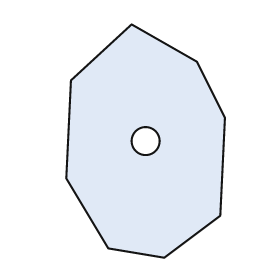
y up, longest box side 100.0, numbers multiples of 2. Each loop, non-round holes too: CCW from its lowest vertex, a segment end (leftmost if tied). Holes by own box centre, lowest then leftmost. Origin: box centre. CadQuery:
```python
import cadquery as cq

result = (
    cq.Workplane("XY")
    .moveTo(8.0, -50.0)
    .lineTo(32.0, -32.0)
    .lineTo(34.0, 10.0)
    .lineTo(22.0, 34.0)
    .lineTo(-6.0, 50.0)
    .lineTo(-32.0, 26.0)
    .lineTo(-34.0, -16.0)
    .lineTo(-16.0, -46.0)
    .close()
    .moveTo(0.0, 0.0)
    .circle(6.0)
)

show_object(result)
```